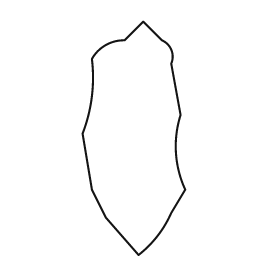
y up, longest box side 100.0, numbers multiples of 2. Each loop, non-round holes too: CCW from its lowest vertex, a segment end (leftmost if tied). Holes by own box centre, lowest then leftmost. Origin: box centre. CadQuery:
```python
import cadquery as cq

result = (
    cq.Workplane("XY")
    .moveTo(2.0, -50.0)
    .threePointArc((10.0, -42.0), (16.0, -32.0))
    .lineTo(22.0, -22.0)
    .threePointArc((18.0, -6.0), (20.0, 10.0))
    .lineTo(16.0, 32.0)
    .threePointArc((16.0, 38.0), (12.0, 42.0))
    .lineTo(4.0, 50.0)
    .lineTo(-4.0, 42.0)
    .threePointArc((-12.0, 40.0), (-18.0, 34.0))
    .threePointArc((-18.0, 18.0), (-22.0, 2.0))
    .lineTo(-18.0, -22.0)
    .lineTo(-12.0, -34.0)
    .close()
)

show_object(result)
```